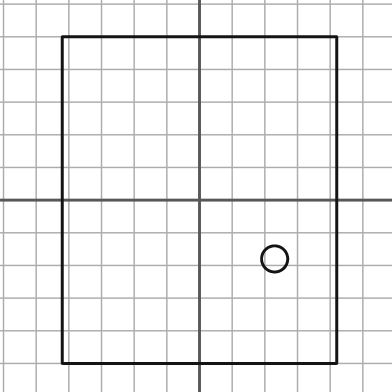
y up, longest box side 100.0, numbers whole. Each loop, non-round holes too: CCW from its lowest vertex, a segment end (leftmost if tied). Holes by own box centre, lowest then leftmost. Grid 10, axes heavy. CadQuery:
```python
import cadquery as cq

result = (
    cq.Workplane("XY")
    .moveTo(-42.0, -50.0)
    .lineTo(42.0, -50.0)
    .lineTo(42.0, 50.0)
    .lineTo(-42.0, 50.0)
    .close()
    .moveTo(23.0, -18.0)
    .circle(4.0)
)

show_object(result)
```